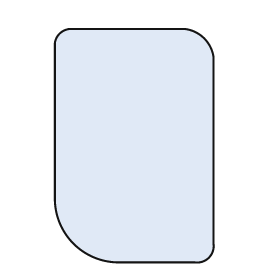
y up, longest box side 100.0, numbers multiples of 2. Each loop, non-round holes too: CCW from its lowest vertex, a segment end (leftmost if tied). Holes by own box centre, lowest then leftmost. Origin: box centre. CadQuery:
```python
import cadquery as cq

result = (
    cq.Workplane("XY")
    .moveTo(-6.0, -50.0)
    .lineTo(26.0, -50.0)
    .threePointArc((32.0, -48.0), (34.0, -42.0))
    .lineTo(34.0, 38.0)
    .threePointArc((30.0, 46.0), (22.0, 50.0))
    .lineTo(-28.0, 50.0)
    .threePointArc((-32.0, 48.0), (-34.0, 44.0))
    .lineTo(-34.0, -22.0)
    .threePointArc((-26.0, -42.0), (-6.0, -50.0))
    .close()
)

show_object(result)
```